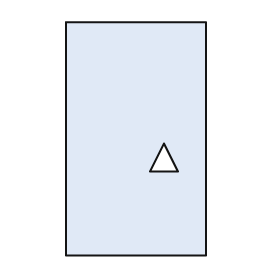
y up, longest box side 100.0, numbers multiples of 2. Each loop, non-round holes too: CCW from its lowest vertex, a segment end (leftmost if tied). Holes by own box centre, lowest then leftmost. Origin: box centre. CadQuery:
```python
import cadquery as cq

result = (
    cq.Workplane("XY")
    .moveTo(-30.0, -50.0)
    .lineTo(30.0, -50.0)
    .lineTo(30.0, 50.0)
    .lineTo(-30.0, 50.0)
    .close()
    .moveTo(6.0, -14.0)
    .lineTo(18.0, -14.0)
    .lineTo(12.0, -2.0)
    .close()
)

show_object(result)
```